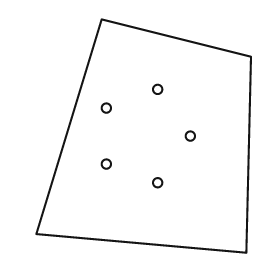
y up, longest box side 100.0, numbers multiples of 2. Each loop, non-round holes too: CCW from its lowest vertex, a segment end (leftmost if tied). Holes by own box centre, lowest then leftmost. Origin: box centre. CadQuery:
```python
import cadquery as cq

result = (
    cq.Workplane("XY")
    .moveTo(44.0, -50.0)
    .lineTo(46.0, 34.0)
    .lineTo(-18.0, 50.0)
    .lineTo(-46.0, -42.0)
    .close()
    .moveTo(6.0, -20.0)
    .circle(2.0)
    .moveTo(-16.0, -12.0)
    .circle(2.0)
    .moveTo(20.0, 0.0)
    .circle(2.0)
    .moveTo(-16.0, 12.0)
    .circle(2.0)
    .moveTo(6.0, 20.0)
    .circle(2.0)
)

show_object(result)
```